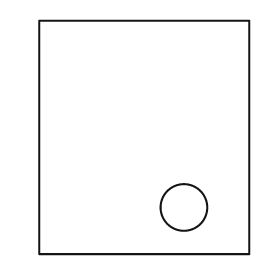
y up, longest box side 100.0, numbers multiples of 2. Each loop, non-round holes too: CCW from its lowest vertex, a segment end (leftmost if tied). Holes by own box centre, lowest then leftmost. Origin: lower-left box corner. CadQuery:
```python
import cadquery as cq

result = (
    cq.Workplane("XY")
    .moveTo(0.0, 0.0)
    .lineTo(90.0, 0.0)
    .lineTo(90.0, 100.0)
    .lineTo(0.0, 100.0)
    .close()
    .moveTo(62.0, 20.0)
    .circle(10.0)
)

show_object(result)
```